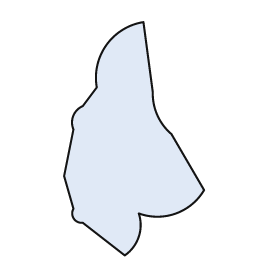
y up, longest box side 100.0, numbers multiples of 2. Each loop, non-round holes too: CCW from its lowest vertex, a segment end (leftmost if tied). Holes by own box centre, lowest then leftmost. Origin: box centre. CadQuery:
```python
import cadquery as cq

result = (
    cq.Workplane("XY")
    .moveTo(-4.0, -50.0)
    .threePointArc((2.0, -42.0), (2.0, -32.0))
    .threePointArc((18.0, -32.0), (30.0, -22.0))
    .lineTo(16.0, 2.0)
    .threePointArc((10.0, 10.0), (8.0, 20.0))
    .lineTo(4.0, 50.0)
    .threePointArc((-12.0, 40.0), (-16.0, 22.0))
    .lineTo(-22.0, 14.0)
    .threePointArc((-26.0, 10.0), (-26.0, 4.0))
    .lineTo(-30.0, -16.0)
    .lineTo(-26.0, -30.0)
    .threePointArc((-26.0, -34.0), (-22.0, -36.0))
    .close()
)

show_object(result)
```